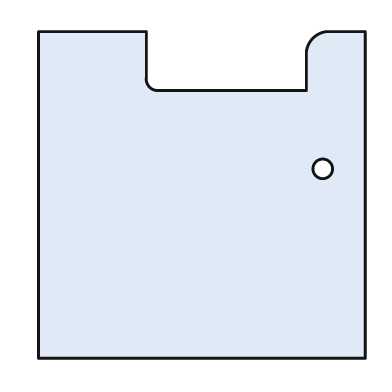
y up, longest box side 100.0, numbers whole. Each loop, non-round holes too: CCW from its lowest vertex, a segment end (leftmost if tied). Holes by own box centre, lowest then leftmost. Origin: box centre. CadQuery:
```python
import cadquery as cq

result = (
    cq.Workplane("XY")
    .moveTo(-50.0, -50.0)
    .lineTo(50.0, -50.0)
    .lineTo(50.0, 50.0)
    .lineTo(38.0, 50.0)
    .threePointArc((34.0, 48.0), (32.0, 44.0))
    .lineTo(32.0, 32.0)
    .lineTo(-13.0, 32.0)
    .threePointArc((-16.0, 33.0), (-17.0, 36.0))
    .lineTo(-17.0, 50.0)
    .lineTo(-50.0, 50.0)
    .close()
    .moveTo(37.0, 8.0)
    .circle(3.0)
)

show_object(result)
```